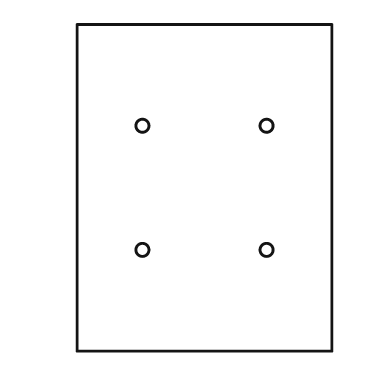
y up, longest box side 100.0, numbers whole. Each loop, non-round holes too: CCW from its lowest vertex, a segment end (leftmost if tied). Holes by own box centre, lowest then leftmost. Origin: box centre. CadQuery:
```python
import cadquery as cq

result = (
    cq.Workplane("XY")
    .moveTo(-39.0, -50.0)
    .lineTo(39.0, -50.0)
    .lineTo(39.0, 50.0)
    .lineTo(-39.0, 50.0)
    .close()
    .moveTo(-19.0, -19.0)
    .circle(2.0)
    .moveTo(19.0, -19.0)
    .circle(2.0)
    .moveTo(-19.0, 19.0)
    .circle(2.0)
    .moveTo(19.0, 19.0)
    .circle(2.0)
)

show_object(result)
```